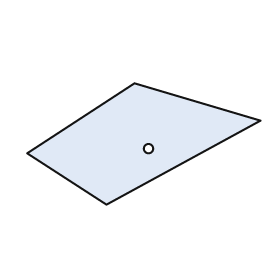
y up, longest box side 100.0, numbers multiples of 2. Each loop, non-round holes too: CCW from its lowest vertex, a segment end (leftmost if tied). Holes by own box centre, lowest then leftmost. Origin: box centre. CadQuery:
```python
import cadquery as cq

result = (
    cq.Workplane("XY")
    .moveTo(-16.0, -26.0)
    .lineTo(50.0, 10.0)
    .lineTo(-4.0, 26.0)
    .lineTo(-50.0, -4.0)
    .close()
    .moveTo(2.0, -2.0)
    .circle(2.0)
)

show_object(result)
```